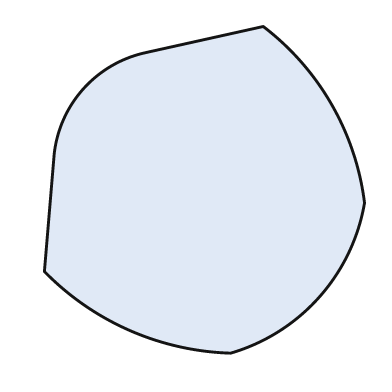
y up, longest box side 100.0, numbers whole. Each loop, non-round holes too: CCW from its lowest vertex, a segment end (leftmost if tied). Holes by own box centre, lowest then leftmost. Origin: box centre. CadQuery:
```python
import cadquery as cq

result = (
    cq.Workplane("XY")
    .moveTo(8.0, -50.0)
    .threePointArc((35.0, -33.0), (49.0, -4.0))
    .threePointArc((39.0, 26.0), (18.0, 50.0))
    .lineTo(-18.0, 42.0)
    .threePointArc((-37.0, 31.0), (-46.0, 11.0))
    .lineTo(-49.0, -25.0)
    .threePointArc((-23.0, -43.0), (8.0, -50.0))
    .close()
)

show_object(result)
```